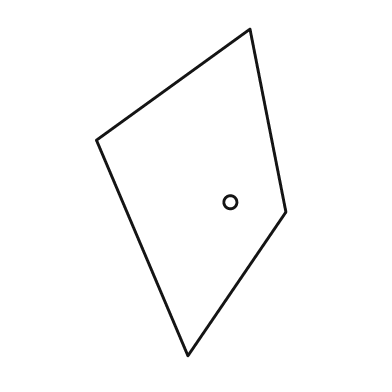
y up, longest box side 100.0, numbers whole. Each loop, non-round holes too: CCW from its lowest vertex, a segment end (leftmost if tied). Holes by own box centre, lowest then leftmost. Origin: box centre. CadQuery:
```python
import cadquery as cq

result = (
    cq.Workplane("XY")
    .moveTo(-1.0, -50.0)
    .lineTo(29.0, -6.0)
    .lineTo(18.0, 50.0)
    .lineTo(-29.0, 16.0)
    .close()
    .moveTo(12.0, -3.0)
    .circle(2.0)
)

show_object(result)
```